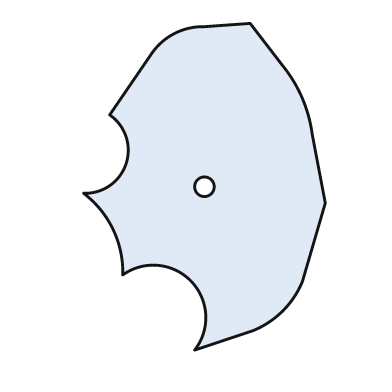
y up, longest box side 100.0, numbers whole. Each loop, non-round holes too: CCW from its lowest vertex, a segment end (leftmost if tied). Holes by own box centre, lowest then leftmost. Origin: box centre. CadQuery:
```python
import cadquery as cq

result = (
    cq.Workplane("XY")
    .moveTo(-3.0, -50.0)
    .lineTo(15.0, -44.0)
    .threePointArc((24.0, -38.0), (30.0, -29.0))
    .lineTo(37.0, -5.0)
    .lineTo(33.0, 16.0)
    .threePointArc((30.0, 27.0), (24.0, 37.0))
    .lineTo(14.0, 50.0)
    .lineTo(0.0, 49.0)
    .threePointArc((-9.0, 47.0), (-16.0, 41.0))
    .lineTo(-29.0, 22.0)
    .threePointArc((-24.0, 7.0), (-37.0, -2.0))
    .threePointArc((-28.0, -13.0), (-25.0, -27.0))
    .threePointArc((-4.0, -29.0), (-3.0, -50.0))
    .close()
    .moveTo(0.0, 0.0)
    .circle(3.0)
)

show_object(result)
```